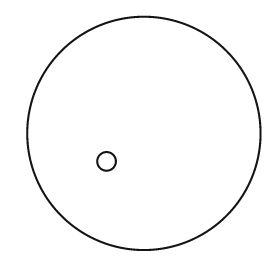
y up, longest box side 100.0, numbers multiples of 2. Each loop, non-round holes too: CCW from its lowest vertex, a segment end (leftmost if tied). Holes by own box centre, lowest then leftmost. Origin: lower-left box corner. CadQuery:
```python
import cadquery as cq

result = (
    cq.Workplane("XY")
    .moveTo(50.0, 50.0)
    .circle(50.0)
    .moveTo(34.0, 38.0)
    .circle(4.0)
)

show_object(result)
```